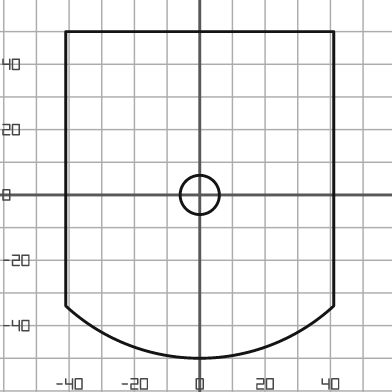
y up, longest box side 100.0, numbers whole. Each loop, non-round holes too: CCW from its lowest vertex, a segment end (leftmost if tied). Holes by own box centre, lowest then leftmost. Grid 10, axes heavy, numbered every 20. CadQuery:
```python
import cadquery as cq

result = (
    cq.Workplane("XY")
    .moveTo(-41.0, -34.0)
    .threePointArc((0.0, -50.0), (41.0, -34.0))
    .lineTo(41.0, 50.0)
    .lineTo(-41.0, 50.0)
    .close()
    .moveTo(0.0, 0.0)
    .circle(6.0)
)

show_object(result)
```